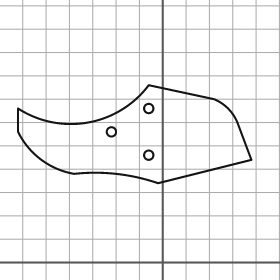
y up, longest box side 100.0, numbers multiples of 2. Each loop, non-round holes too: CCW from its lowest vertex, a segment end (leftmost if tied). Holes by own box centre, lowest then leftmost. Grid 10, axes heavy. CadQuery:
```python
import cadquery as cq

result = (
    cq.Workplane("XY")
    .moveTo(-2.0, 34.0)
    .lineTo(38.0, 44.0)
    .lineTo(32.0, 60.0)
    .threePointArc((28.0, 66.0), (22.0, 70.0))
    .lineTo(-6.0, 76.0)
    .threePointArc((-32.0, 60.0), (-62.0, 66.0))
    .lineTo(-62.0, 56.0)
    .threePointArc((-52.0, 44.0), (-38.0, 38.0))
    .threePointArc((-20.0, 38.0), (-2.0, 34.0))
    .close()
    .moveTo(-6.0, 46.0)
    .circle(2.0)
    .moveTo(-22.0, 56.0)
    .circle(2.0)
    .moveTo(-6.0, 66.0)
    .circle(2.0)
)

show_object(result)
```